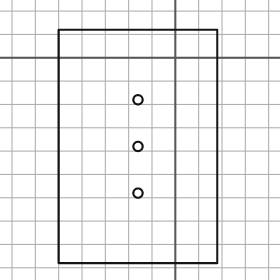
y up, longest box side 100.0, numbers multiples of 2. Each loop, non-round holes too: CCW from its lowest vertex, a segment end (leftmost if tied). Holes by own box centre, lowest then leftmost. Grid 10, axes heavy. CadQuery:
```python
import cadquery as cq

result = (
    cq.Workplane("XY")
    .moveTo(-50.0, -88.0)
    .lineTo(18.0, -88.0)
    .lineTo(18.0, 12.0)
    .lineTo(-50.0, 12.0)
    .close()
    .moveTo(-16.0, -58.0)
    .circle(2.0)
    .moveTo(-16.0, -38.0)
    .circle(2.0)
    .moveTo(-16.0, -18.0)
    .circle(2.0)
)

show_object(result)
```